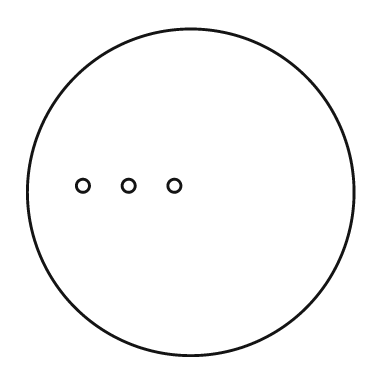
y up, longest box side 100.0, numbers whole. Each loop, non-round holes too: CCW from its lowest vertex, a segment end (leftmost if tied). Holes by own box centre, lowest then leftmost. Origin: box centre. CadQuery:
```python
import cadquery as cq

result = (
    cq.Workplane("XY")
    .moveTo(0.0, 0.0)
    .circle(50.0)
    .moveTo(-33.0, 2.0)
    .circle(2.0)
    .moveTo(-19.0, 2.0)
    .circle(2.0)
    .moveTo(-5.0, 2.0)
    .circle(2.0)
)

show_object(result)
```